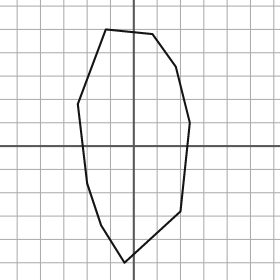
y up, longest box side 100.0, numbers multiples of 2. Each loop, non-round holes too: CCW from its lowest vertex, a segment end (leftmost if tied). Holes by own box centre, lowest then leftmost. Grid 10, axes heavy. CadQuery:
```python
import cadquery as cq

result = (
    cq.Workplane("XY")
    .moveTo(-4.0, -50.0)
    .lineTo(20.0, -28.0)
    .lineTo(24.0, 10.0)
    .lineTo(18.0, 34.0)
    .lineTo(8.0, 48.0)
    .lineTo(-12.0, 50.0)
    .lineTo(-24.0, 18.0)
    .lineTo(-20.0, -16.0)
    .lineTo(-14.0, -34.0)
    .close()
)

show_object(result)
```